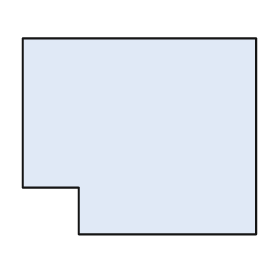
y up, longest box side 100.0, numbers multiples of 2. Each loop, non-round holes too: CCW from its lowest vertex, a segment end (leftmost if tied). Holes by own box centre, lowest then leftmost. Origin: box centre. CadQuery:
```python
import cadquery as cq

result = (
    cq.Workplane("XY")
    .moveTo(-26.0, -42.0)
    .lineTo(50.0, -42.0)
    .lineTo(50.0, 42.0)
    .lineTo(-50.0, 42.0)
    .lineTo(-50.0, -22.0)
    .lineTo(-26.0, -22.0)
    .close()
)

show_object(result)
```